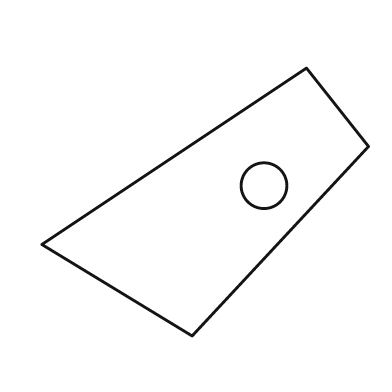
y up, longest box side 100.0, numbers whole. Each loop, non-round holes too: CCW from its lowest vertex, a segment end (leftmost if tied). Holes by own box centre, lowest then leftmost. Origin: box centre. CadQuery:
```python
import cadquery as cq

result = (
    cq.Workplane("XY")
    .moveTo(-4.0, -41.0)
    .lineTo(50.0, 17.0)
    .lineTo(31.0, 41.0)
    .lineTo(-50.0, -13.0)
    .close()
    .moveTo(18.0, 5.0)
    .circle(7.0)
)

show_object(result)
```